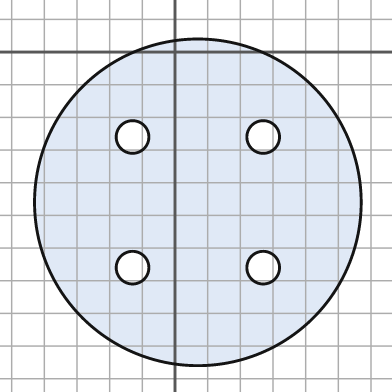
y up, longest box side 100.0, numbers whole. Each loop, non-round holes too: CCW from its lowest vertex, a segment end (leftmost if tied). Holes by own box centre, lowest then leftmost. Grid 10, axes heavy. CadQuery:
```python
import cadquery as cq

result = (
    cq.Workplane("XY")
    .moveTo(7.0, -46.0)
    .circle(50.0)
    .moveTo(-13.0, -66.0)
    .circle(5.0)
    .moveTo(27.0, -66.0)
    .circle(5.0)
    .moveTo(-13.0, -26.0)
    .circle(5.0)
    .moveTo(27.0, -26.0)
    .circle(5.0)
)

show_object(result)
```